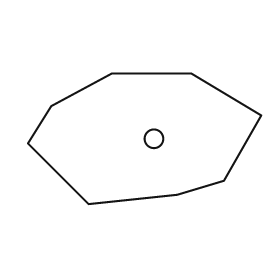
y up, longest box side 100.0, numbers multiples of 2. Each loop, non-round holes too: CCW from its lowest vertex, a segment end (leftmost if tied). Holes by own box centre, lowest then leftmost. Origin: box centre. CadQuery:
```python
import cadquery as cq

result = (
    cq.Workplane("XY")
    .moveTo(-24.0, -28.0)
    .lineTo(14.0, -24.0)
    .lineTo(34.0, -18.0)
    .lineTo(50.0, 10.0)
    .lineTo(20.0, 28.0)
    .lineTo(-14.0, 28.0)
    .lineTo(-40.0, 14.0)
    .lineTo(-50.0, -2.0)
    .close()
    .moveTo(4.0, 0.0)
    .circle(4.0)
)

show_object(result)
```